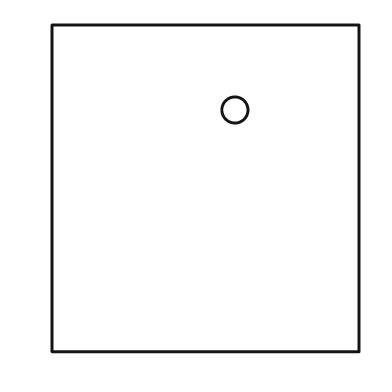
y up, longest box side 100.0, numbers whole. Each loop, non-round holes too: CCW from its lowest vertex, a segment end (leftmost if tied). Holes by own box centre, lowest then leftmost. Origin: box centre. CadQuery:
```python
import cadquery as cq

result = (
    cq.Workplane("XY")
    .moveTo(-47.0, -50.0)
    .lineTo(47.0, -50.0)
    .lineTo(47.0, 50.0)
    .lineTo(-47.0, 50.0)
    .close()
    .moveTo(9.0, 24.0)
    .circle(4.0)
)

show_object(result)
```